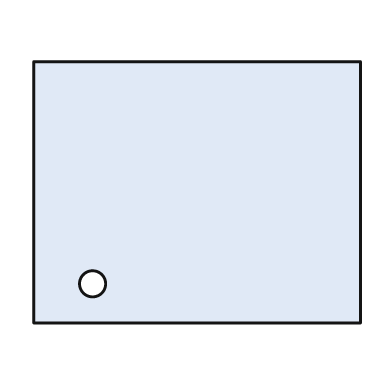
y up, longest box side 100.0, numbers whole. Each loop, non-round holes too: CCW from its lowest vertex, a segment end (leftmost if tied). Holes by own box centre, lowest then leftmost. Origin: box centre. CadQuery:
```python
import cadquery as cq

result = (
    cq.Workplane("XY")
    .moveTo(-50.0, -40.0)
    .lineTo(50.0, -40.0)
    .lineTo(50.0, 40.0)
    .lineTo(-50.0, 40.0)
    .close()
    .moveTo(-32.0, -28.0)
    .circle(4.0)
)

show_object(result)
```